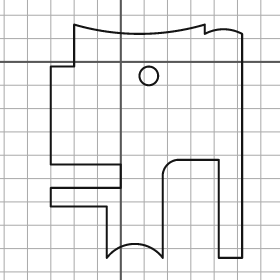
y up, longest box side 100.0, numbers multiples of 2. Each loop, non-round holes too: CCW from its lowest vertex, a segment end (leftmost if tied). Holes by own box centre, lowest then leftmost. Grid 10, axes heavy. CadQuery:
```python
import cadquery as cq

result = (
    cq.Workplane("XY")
    .moveTo(-6.0, -84.0)
    .threePointArc((6.0, -78.0), (18.0, -84.0))
    .lineTo(18.0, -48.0)
    .threePointArc((20.0, -44.0), (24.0, -42.0))
    .lineTo(42.0, -42.0)
    .lineTo(42.0, -84.0)
    .lineTo(52.0, -84.0)
    .lineTo(52.0, 12.0)
    .threePointArc((44.0, 14.0), (36.0, 12.0))
    .lineTo(36.0, 16.0)
    .threePointArc((8.0, 12.0), (-20.0, 16.0))
    .lineTo(-20.0, -2.0)
    .lineTo(-30.0, -2.0)
    .lineTo(-30.0, -44.0)
    .lineTo(0.0, -44.0)
    .lineTo(0.0, -54.0)
    .lineTo(-30.0, -54.0)
    .lineTo(-30.0, -62.0)
    .lineTo(-6.0, -62.0)
    .close()
    .moveTo(12.0, -6.0)
    .circle(4.0)
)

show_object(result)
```